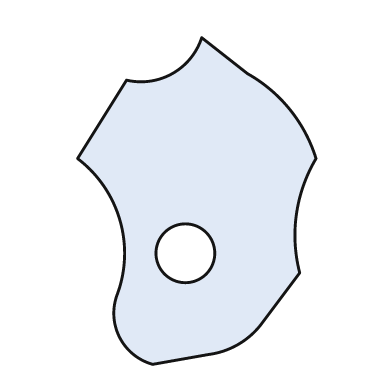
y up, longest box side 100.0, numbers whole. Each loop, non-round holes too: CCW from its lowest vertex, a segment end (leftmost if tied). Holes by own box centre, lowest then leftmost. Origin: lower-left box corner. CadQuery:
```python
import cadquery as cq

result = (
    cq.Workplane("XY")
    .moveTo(23.0, 0.0)
    .lineTo(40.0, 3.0)
    .threePointArc((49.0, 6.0), (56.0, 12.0))
    .lineTo(68.0, 28.0)
    .threePointArc((67.0, 46.0), (73.0, 63.0))
    .threePointArc((65.0, 78.0), (52.0, 89.0))
    .lineTo(38.0, 100.0)
    .threePointArc((29.0, 89.0), (15.0, 87.0))
    .lineTo(0.0, 63.0)
    .threePointArc((13.0, 44.0), (12.0, 21.0))
    .threePointArc((13.0, 8.0), (23.0, 0.0))
    .close()
    .moveTo(33.0, 34.0)
    .circle(9.0)
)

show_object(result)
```